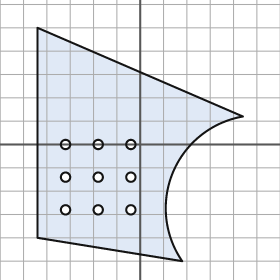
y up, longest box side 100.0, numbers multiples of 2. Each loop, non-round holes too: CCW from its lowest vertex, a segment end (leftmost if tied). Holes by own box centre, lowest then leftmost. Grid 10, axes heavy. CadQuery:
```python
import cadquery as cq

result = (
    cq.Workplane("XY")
    .moveTo(18.0, -50.0)
    .threePointArc((14.0, -12.0), (44.0, 12.0))
    .lineTo(-44.0, 50.0)
    .lineTo(-44.0, -40.0)
    .close()
    .moveTo(-32.0, -28.0)
    .circle(2.0)
    .moveTo(-18.0, -28.0)
    .circle(2.0)
    .moveTo(-4.0, -28.0)
    .circle(2.0)
    .moveTo(-32.0, -14.0)
    .circle(2.0)
    .moveTo(-18.0, -14.0)
    .circle(2.0)
    .moveTo(-4.0, -14.0)
    .circle(2.0)
    .moveTo(-32.0, 0.0)
    .circle(2.0)
    .moveTo(-18.0, 0.0)
    .circle(2.0)
    .moveTo(-4.0, 0.0)
    .circle(2.0)
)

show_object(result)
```